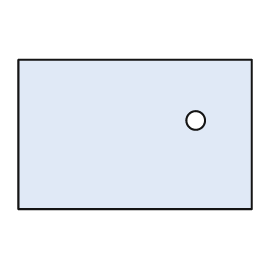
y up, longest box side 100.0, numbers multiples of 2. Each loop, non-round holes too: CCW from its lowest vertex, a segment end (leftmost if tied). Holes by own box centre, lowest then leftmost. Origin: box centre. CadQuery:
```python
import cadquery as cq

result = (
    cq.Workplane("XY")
    .moveTo(-50.0, -32.0)
    .lineTo(50.0, -32.0)
    .lineTo(50.0, 32.0)
    .lineTo(-50.0, 32.0)
    .close()
    .moveTo(26.0, 6.0)
    .circle(4.0)
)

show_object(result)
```